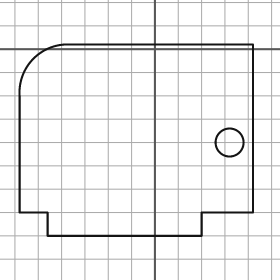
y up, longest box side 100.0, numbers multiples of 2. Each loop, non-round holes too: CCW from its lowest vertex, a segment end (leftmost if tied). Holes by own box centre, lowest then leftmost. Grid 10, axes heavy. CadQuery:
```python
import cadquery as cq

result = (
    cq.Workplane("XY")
    .moveTo(-46.0, -80.0)
    .lineTo(20.0, -80.0)
    .lineTo(20.0, -70.0)
    .lineTo(42.0, -70.0)
    .lineTo(42.0, 2.0)
    .lineTo(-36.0, 2.0)
    .threePointArc((-52.0, -4.0), (-58.0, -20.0))
    .lineTo(-58.0, -70.0)
    .lineTo(-46.0, -70.0)
    .close()
    .moveTo(32.0, -40.0)
    .circle(6.0)
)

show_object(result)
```